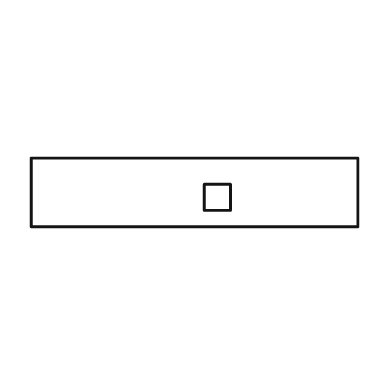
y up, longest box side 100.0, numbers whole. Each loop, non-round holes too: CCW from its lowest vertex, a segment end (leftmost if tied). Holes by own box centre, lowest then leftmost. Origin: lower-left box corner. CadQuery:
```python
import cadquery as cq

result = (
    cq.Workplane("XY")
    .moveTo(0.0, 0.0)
    .lineTo(100.0, 0.0)
    .lineTo(100.0, 21.0)
    .lineTo(0.0, 21.0)
    .close()
    .moveTo(53.0, 5.0)
    .lineTo(61.0, 5.0)
    .lineTo(61.0, 13.0)
    .lineTo(53.0, 13.0)
    .close()
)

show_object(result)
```